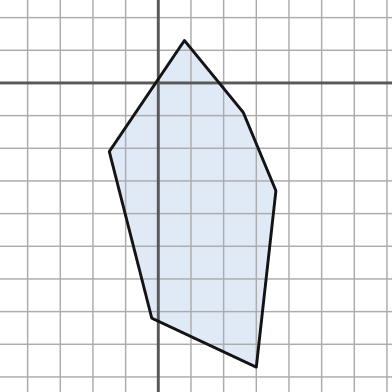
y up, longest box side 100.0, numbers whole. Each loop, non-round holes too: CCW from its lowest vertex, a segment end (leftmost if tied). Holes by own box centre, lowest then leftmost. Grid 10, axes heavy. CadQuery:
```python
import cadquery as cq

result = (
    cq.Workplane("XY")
    .moveTo(30.0, -87.0)
    .lineTo(36.0, -33.0)
    .lineTo(26.0, -9.0)
    .lineTo(8.0, 13.0)
    .lineTo(-15.0, -21.0)
    .lineTo(-2.0, -72.0)
    .close()
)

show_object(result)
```